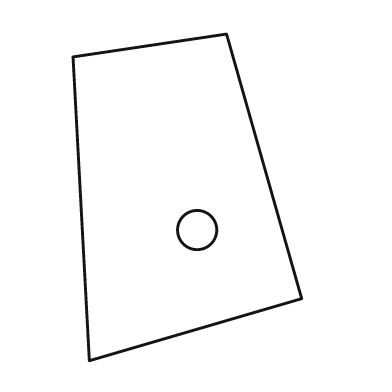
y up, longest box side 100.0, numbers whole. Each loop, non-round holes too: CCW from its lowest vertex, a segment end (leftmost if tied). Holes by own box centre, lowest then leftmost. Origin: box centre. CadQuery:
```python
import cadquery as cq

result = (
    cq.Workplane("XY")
    .moveTo(-30.0, -50.0)
    .lineTo(35.0, -31.0)
    .lineTo(12.0, 50.0)
    .lineTo(-35.0, 43.0)
    .close()
    .moveTo(3.0, -10.0)
    .circle(6.0)
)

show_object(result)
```